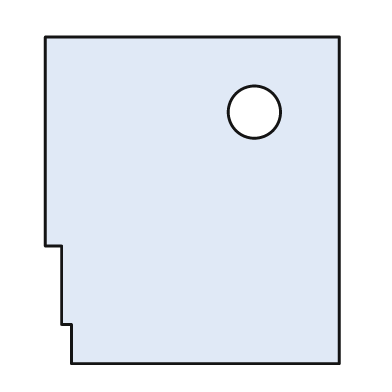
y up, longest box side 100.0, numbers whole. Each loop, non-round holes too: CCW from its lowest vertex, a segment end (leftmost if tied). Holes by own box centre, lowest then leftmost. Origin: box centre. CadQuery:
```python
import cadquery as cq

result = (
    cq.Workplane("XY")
    .moveTo(-37.0, -50.0)
    .lineTo(45.0, -50.0)
    .lineTo(45.0, 50.0)
    .lineTo(-45.0, 50.0)
    .lineTo(-45.0, -14.0)
    .lineTo(-40.0, -14.0)
    .lineTo(-40.0, -38.0)
    .lineTo(-37.0, -38.0)
    .close()
    .moveTo(19.0, 27.0)
    .circle(8.0)
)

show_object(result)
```